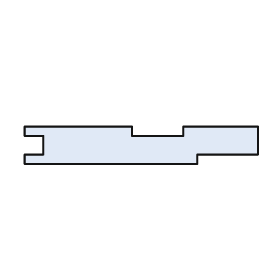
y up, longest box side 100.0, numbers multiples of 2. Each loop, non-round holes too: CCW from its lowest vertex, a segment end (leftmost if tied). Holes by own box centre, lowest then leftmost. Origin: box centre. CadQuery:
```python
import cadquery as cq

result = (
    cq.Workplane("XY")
    .moveTo(-50.0, -8.0)
    .lineTo(24.0, -8.0)
    .lineTo(24.0, -4.0)
    .lineTo(50.0, -4.0)
    .lineTo(50.0, 8.0)
    .lineTo(18.0, 8.0)
    .lineTo(18.0, 4.0)
    .lineTo(-4.0, 4.0)
    .lineTo(-4.0, 8.0)
    .lineTo(-50.0, 8.0)
    .lineTo(-50.0, 4.0)
    .lineTo(-42.0, 4.0)
    .lineTo(-42.0, -4.0)
    .lineTo(-50.0, -4.0)
    .close()
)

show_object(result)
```